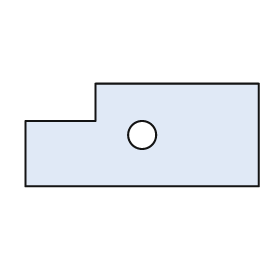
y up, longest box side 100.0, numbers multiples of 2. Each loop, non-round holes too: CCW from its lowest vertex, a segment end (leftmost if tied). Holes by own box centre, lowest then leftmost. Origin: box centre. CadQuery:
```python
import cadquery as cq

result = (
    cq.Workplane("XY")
    .moveTo(-50.0, -22.0)
    .lineTo(50.0, -22.0)
    .lineTo(50.0, 22.0)
    .lineTo(-20.0, 22.0)
    .lineTo(-20.0, 6.0)
    .lineTo(-50.0, 6.0)
    .close()
    .moveTo(0.0, 0.0)
    .circle(6.0)
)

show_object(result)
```